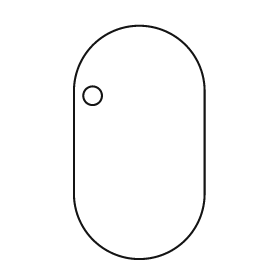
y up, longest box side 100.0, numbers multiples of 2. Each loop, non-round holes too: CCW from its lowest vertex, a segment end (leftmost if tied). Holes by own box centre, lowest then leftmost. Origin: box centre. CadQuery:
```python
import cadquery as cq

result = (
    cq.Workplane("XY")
    .moveTo(-28.0, -22.0)
    .threePointArc((0.0, -50.0), (28.0, -22.0))
    .lineTo(28.0, 22.0)
    .threePointArc((0.0, 50.0), (-28.0, 22.0))
    .close()
    .moveTo(-20.0, 20.0)
    .circle(4.0)
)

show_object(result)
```